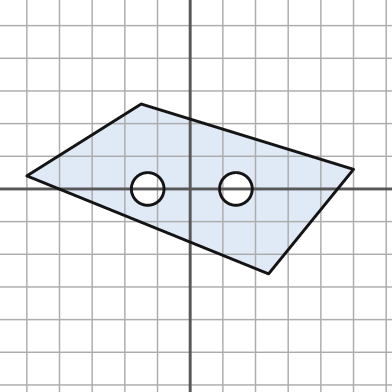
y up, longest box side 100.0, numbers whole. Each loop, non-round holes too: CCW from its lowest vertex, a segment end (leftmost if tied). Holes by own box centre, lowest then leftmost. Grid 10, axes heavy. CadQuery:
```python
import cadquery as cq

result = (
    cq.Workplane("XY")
    .moveTo(24.0, -26.0)
    .lineTo(50.0, 6.0)
    .lineTo(-15.0, 26.0)
    .lineTo(-50.0, 4.0)
    .close()
    .moveTo(-13.0, 0.0)
    .circle(5.0)
    .moveTo(14.0, 0.0)
    .circle(5.0)
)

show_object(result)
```